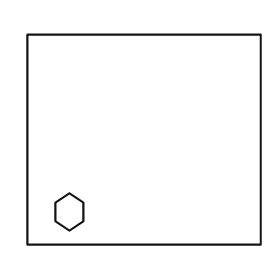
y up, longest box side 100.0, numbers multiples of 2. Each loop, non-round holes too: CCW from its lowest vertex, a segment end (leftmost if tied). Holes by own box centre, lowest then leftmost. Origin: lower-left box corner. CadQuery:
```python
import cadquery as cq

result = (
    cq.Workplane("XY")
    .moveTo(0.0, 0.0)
    .lineTo(100.0, 0.0)
    .lineTo(100.0, 90.0)
    .lineTo(0.0, 90.0)
    .close()
    .moveTo(18.0, 6.0)
    .lineTo(24.0, 10.0)
    .lineTo(24.0, 18.0)
    .lineTo(18.0, 22.0)
    .lineTo(12.0, 18.0)
    .lineTo(12.0, 10.0)
    .close()
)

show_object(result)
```